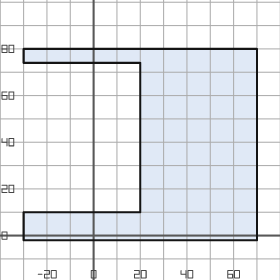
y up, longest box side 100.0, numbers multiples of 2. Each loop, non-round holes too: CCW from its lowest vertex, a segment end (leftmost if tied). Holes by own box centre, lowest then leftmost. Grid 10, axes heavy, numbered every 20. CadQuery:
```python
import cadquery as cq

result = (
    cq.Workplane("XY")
    .moveTo(-30.0, -2.0)
    .lineTo(70.0, -2.0)
    .lineTo(70.0, 80.0)
    .lineTo(-30.0, 80.0)
    .lineTo(-30.0, 74.0)
    .lineTo(20.0, 74.0)
    .lineTo(20.0, 10.0)
    .lineTo(-30.0, 10.0)
    .close()
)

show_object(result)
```